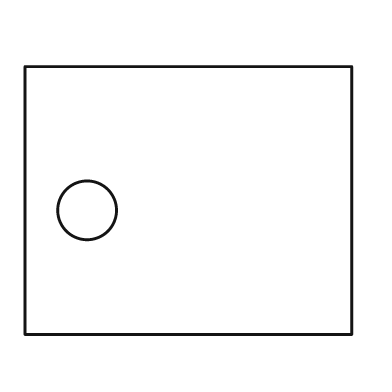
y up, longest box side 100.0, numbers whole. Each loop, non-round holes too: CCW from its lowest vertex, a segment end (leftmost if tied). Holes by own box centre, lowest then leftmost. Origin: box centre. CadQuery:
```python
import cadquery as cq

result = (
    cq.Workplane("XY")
    .moveTo(-50.0, -41.0)
    .lineTo(50.0, -41.0)
    .lineTo(50.0, 41.0)
    .lineTo(-50.0, 41.0)
    .close()
    .moveTo(-31.0, -3.0)
    .circle(9.0)
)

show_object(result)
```